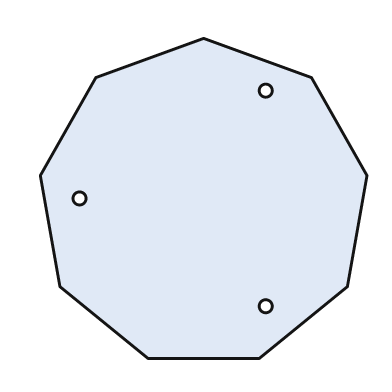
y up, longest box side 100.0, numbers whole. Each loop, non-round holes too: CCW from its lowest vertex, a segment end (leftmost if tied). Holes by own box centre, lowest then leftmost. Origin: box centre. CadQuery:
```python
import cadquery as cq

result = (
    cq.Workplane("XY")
    .moveTo(-17.0, -49.0)
    .lineTo(17.0, -49.0)
    .lineTo(44.0, -27.0)
    .lineTo(50.0, 7.0)
    .lineTo(33.0, 37.0)
    .lineTo(0.0, 49.0)
    .lineTo(-33.0, 37.0)
    .lineTo(-50.0, 7.0)
    .lineTo(-44.0, -27.0)
    .close()
    .moveTo(19.0, -33.0)
    .circle(2.0)
    .moveTo(-38.0, 0.0)
    .circle(2.0)
    .moveTo(19.0, 33.0)
    .circle(2.0)
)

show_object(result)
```